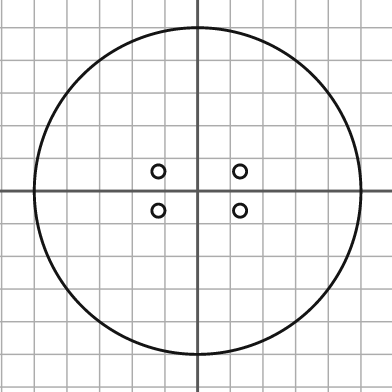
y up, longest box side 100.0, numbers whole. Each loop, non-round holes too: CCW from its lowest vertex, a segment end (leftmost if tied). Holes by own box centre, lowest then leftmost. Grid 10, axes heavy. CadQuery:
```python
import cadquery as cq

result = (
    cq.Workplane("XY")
    .moveTo(0.0, 0.0)
    .circle(50.0)
    .moveTo(-12.0, -6.0)
    .circle(2.0)
    .moveTo(13.0, -6.0)
    .circle(2.0)
    .moveTo(-12.0, 6.0)
    .circle(2.0)
    .moveTo(13.0, 6.0)
    .circle(2.0)
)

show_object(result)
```